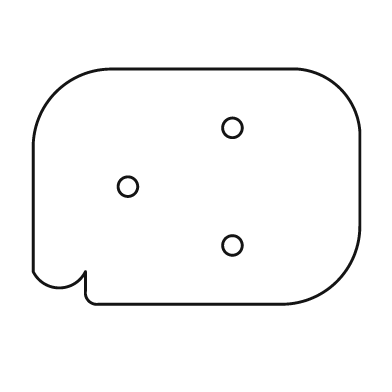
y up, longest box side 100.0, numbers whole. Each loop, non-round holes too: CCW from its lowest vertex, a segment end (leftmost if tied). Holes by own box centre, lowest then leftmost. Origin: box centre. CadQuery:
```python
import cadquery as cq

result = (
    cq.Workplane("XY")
    .moveTo(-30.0, -36.0)
    .lineTo(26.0, -36.0)
    .threePointArc((43.0, -29.0), (50.0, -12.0))
    .lineTo(50.0, 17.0)
    .threePointArc((44.0, 30.0), (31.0, 36.0))
    .lineTo(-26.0, 36.0)
    .threePointArc((-43.0, 29.0), (-50.0, 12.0))
    .lineTo(-50.0, -26.0)
    .threePointArc((-42.0, -31.0), (-34.0, -26.0))
    .lineTo(-34.0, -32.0)
    .threePointArc((-33.0, -35.0), (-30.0, -36.0))
    .close()
    .moveTo(11.0, -18.0)
    .circle(3.0)
    .moveTo(-21.0, 0.0)
    .circle(3.0)
    .moveTo(11.0, 18.0)
    .circle(3.0)
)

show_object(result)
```